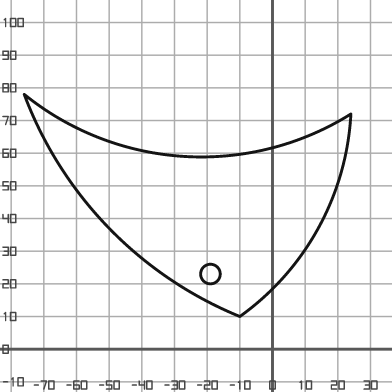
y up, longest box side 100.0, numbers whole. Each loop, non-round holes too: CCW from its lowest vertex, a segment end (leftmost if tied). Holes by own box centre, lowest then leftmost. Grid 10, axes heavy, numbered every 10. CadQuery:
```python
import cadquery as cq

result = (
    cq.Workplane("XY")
    .moveTo(-10.0, 10.0)
    .threePointArc((14.0, 37.0), (24.0, 72.0))
    .threePointArc((-27.0, 59.0), (-76.0, 78.0))
    .threePointArc((-50.0, 37.0), (-10.0, 10.0))
    .close()
    .moveTo(-19.0, 23.0)
    .circle(3.0)
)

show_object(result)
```